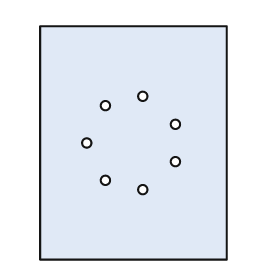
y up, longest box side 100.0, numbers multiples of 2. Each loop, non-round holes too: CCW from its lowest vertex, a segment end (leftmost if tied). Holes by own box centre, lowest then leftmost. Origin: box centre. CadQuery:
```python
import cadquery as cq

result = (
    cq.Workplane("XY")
    .moveTo(-40.0, -50.0)
    .lineTo(40.0, -50.0)
    .lineTo(40.0, 50.0)
    .lineTo(-40.0, 50.0)
    .close()
    .moveTo(4.0, -20.0)
    .circle(2.0)
    .moveTo(-12.0, -16.0)
    .circle(2.0)
    .moveTo(18.0, -8.0)
    .circle(2.0)
    .moveTo(-20.0, 0.0)
    .circle(2.0)
    .moveTo(18.0, 8.0)
    .circle(2.0)
    .moveTo(-12.0, 16.0)
    .circle(2.0)
    .moveTo(4.0, 20.0)
    .circle(2.0)
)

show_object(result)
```